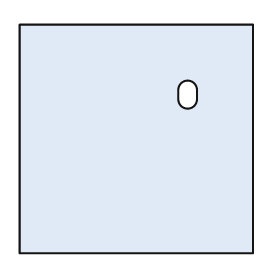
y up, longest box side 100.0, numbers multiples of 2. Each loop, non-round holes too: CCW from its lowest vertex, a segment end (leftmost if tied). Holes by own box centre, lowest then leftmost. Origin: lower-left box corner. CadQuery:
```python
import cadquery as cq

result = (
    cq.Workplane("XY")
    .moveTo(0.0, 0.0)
    .lineTo(100.0, 0.0)
    .lineTo(100.0, 98.0)
    .lineTo(0.0, 98.0)
    .close()
    .moveTo(68.0, 66.0)
    .threePointArc((72.0, 62.0), (76.0, 66.0))
    .lineTo(76.0, 70.0)
    .threePointArc((72.0, 74.0), (68.0, 70.0))
    .close()
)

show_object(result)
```